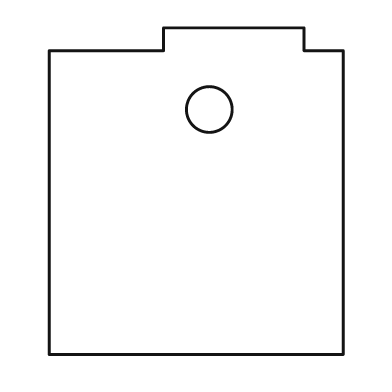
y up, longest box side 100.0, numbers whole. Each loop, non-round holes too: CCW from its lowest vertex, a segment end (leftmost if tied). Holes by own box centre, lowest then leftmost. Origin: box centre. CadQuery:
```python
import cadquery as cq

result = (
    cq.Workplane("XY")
    .moveTo(-45.0, -50.0)
    .lineTo(45.0, -50.0)
    .lineTo(45.0, 43.0)
    .lineTo(33.0, 43.0)
    .lineTo(33.0, 50.0)
    .lineTo(-10.0, 50.0)
    .lineTo(-10.0, 43.0)
    .lineTo(-45.0, 43.0)
    .close()
    .moveTo(4.0, 25.0)
    .circle(7.0)
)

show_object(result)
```